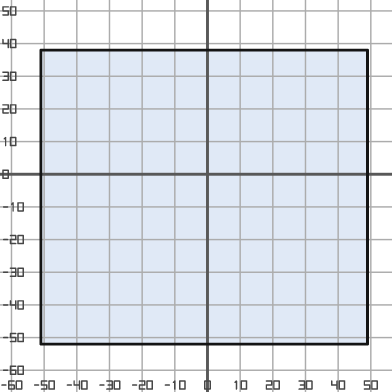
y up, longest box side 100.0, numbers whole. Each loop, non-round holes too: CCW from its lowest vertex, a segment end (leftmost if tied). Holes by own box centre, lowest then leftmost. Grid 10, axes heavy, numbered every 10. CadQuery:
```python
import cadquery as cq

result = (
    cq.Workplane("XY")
    .moveTo(-51.0, -52.0)
    .lineTo(49.0, -52.0)
    .lineTo(49.0, 38.0)
    .lineTo(-51.0, 38.0)
    .close()
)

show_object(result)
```